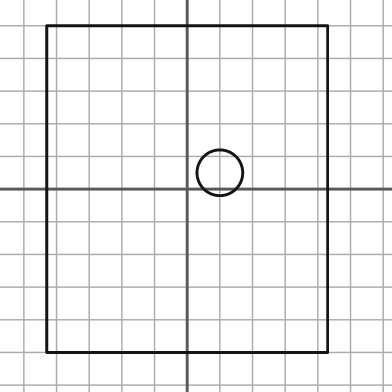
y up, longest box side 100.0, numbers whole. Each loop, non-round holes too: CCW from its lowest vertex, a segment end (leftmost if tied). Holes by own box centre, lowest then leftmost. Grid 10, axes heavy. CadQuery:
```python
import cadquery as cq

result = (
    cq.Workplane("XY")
    .moveTo(-43.0, -50.0)
    .lineTo(43.0, -50.0)
    .lineTo(43.0, 50.0)
    .lineTo(-43.0, 50.0)
    .close()
    .moveTo(10.0, 5.0)
    .circle(7.0)
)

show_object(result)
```